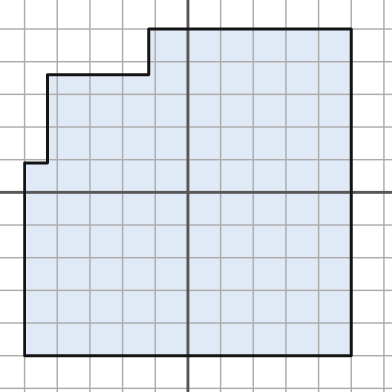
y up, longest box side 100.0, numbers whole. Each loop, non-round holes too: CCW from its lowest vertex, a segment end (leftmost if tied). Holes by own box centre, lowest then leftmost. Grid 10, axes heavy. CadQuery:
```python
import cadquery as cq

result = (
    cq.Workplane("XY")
    .moveTo(-50.0, -50.0)
    .lineTo(50.0, -50.0)
    .lineTo(50.0, 50.0)
    .lineTo(-12.0, 50.0)
    .lineTo(-12.0, 36.0)
    .lineTo(-43.0, 36.0)
    .lineTo(-43.0, 9.0)
    .lineTo(-50.0, 9.0)
    .close()
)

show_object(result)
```